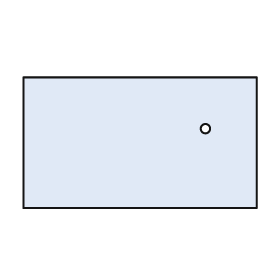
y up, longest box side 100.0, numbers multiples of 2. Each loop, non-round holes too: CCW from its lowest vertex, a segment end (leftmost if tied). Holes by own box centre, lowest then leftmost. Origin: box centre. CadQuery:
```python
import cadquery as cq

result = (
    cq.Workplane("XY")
    .moveTo(-50.0, -28.0)
    .lineTo(50.0, -28.0)
    .lineTo(50.0, 28.0)
    .lineTo(-50.0, 28.0)
    .close()
    .moveTo(28.0, 6.0)
    .circle(2.0)
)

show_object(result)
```